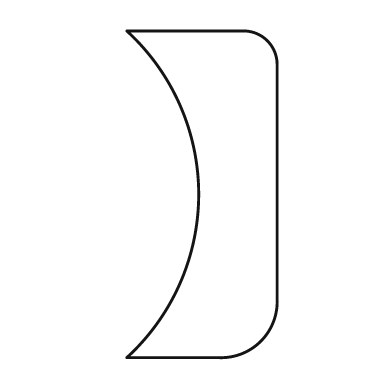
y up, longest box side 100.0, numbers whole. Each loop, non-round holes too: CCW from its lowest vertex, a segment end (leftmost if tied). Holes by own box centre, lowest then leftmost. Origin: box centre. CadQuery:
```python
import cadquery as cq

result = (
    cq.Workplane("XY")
    .moveTo(-23.0, -50.0)
    .lineTo(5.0, -50.0)
    .threePointArc((18.0, -45.0), (23.0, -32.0))
    .lineTo(23.0, 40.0)
    .threePointArc((20.0, 47.0), (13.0, 50.0))
    .lineTo(-23.0, 50.0)
    .threePointArc((-1.0, 0.0), (-23.0, -50.0))
    .close()
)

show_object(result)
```